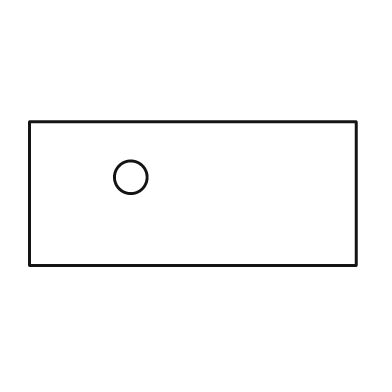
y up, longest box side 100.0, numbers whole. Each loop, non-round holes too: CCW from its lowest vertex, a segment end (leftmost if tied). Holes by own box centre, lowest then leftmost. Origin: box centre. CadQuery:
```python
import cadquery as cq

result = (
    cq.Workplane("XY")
    .moveTo(-50.0, -22.0)
    .lineTo(50.0, -22.0)
    .lineTo(50.0, 22.0)
    .lineTo(-50.0, 22.0)
    .close()
    .moveTo(-19.0, 5.0)
    .circle(5.0)
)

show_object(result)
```